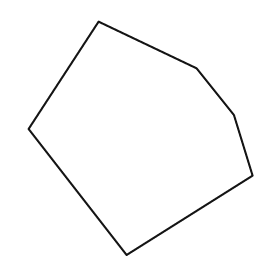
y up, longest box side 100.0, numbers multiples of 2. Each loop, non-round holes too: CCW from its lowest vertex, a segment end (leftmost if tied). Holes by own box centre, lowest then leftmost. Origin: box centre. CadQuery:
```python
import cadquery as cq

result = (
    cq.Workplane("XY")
    .moveTo(-6.0, -50.0)
    .lineTo(48.0, -16.0)
    .lineTo(40.0, 10.0)
    .lineTo(24.0, 30.0)
    .lineTo(-18.0, 50.0)
    .lineTo(-48.0, 4.0)
    .close()
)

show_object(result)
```